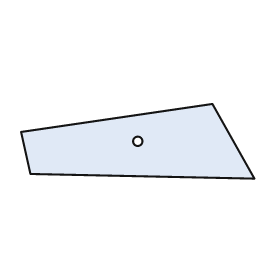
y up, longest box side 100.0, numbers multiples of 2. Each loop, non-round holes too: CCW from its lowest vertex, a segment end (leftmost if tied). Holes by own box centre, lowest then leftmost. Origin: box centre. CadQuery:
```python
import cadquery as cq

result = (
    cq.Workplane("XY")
    .moveTo(50.0, -16.0)
    .lineTo(32.0, 16.0)
    .lineTo(-50.0, 4.0)
    .lineTo(-46.0, -14.0)
    .close()
    .moveTo(0.0, 0.0)
    .circle(2.0)
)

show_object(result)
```